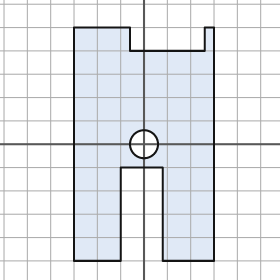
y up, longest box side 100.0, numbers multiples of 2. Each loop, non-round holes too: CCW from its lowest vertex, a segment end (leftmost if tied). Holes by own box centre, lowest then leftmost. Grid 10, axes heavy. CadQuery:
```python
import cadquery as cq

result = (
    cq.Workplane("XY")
    .moveTo(-30.0, -50.0)
    .lineTo(-10.0, -50.0)
    .lineTo(-10.0, -10.0)
    .lineTo(8.0, -10.0)
    .lineTo(8.0, -50.0)
    .lineTo(30.0, -50.0)
    .lineTo(30.0, 50.0)
    .lineTo(26.0, 50.0)
    .lineTo(26.0, 40.0)
    .lineTo(-6.0, 40.0)
    .lineTo(-6.0, 50.0)
    .lineTo(-30.0, 50.0)
    .close()
    .moveTo(0.0, 0.0)
    .circle(6.0)
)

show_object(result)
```